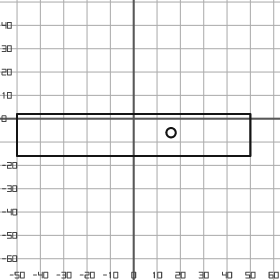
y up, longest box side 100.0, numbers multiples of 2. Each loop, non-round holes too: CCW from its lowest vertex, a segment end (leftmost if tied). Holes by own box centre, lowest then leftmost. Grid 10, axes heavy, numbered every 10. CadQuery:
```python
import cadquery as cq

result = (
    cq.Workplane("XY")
    .moveTo(-50.0, -16.0)
    .lineTo(50.0, -16.0)
    .lineTo(50.0, 2.0)
    .lineTo(-50.0, 2.0)
    .close()
    .moveTo(16.0, -6.0)
    .circle(2.0)
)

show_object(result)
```